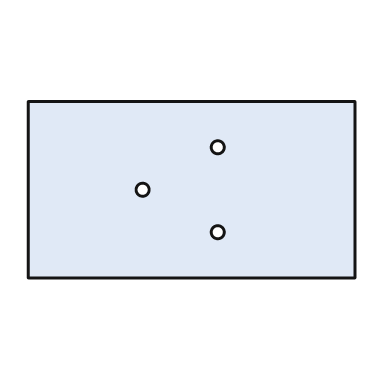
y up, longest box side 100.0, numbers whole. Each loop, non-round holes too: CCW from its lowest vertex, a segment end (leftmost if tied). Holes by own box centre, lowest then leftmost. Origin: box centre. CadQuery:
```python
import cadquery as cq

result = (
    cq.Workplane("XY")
    .moveTo(-50.0, -27.0)
    .lineTo(50.0, -27.0)
    .lineTo(50.0, 27.0)
    .lineTo(-50.0, 27.0)
    .close()
    .moveTo(8.0, -13.0)
    .circle(2.0)
    .moveTo(-15.0, 0.0)
    .circle(2.0)
    .moveTo(8.0, 13.0)
    .circle(2.0)
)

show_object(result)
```